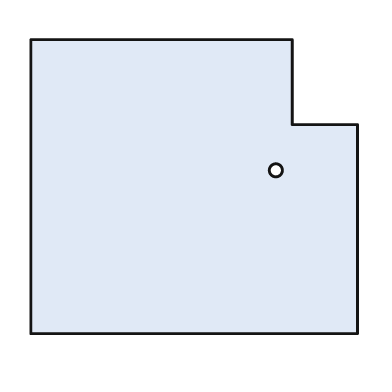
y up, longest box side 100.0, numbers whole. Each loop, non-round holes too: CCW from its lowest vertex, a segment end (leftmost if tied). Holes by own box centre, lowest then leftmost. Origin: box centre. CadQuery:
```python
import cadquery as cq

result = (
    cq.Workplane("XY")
    .moveTo(-50.0, -45.0)
    .lineTo(50.0, -45.0)
    .lineTo(50.0, 19.0)
    .lineTo(30.0, 19.0)
    .lineTo(30.0, 45.0)
    .lineTo(-50.0, 45.0)
    .close()
    .moveTo(25.0, 5.0)
    .circle(2.0)
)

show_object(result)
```